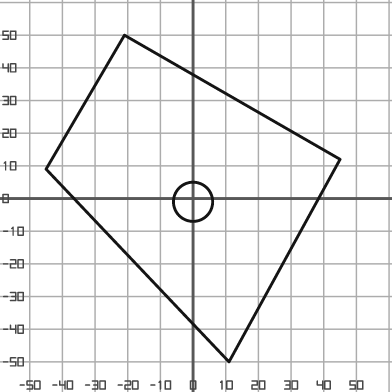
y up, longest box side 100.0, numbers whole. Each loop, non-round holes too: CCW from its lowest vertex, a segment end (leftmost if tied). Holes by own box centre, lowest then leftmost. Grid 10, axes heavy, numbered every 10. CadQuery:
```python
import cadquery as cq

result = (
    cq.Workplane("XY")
    .moveTo(11.0, -50.0)
    .lineTo(45.0, 12.0)
    .lineTo(-21.0, 50.0)
    .lineTo(-45.0, 9.0)
    .close()
    .moveTo(0.0, -1.0)
    .circle(6.0)
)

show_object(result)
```